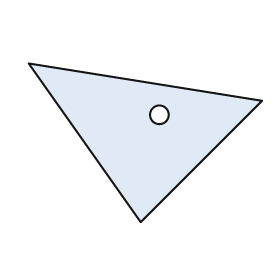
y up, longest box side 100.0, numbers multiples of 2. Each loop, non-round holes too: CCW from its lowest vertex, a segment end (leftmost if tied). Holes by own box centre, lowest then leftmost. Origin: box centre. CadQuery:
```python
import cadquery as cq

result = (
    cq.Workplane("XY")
    .moveTo(-2.0, -34.0)
    .lineTo(50.0, 18.0)
    .lineTo(-50.0, 34.0)
    .close()
    .moveTo(6.0, 12.0)
    .circle(4.0)
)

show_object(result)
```